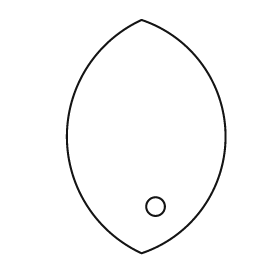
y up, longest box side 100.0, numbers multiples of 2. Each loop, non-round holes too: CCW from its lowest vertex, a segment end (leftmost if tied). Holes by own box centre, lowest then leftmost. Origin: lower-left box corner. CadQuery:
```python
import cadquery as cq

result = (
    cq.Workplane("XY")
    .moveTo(32.0, 0.0)
    .threePointArc((68.0, 50.0), (32.0, 100.0))
    .threePointArc((0.0, 50.0), (32.0, 0.0))
    .close()
    .moveTo(38.0, 20.0)
    .circle(4.0)
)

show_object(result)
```